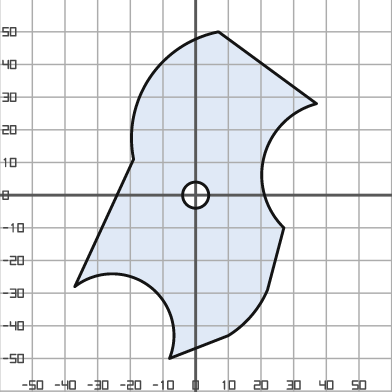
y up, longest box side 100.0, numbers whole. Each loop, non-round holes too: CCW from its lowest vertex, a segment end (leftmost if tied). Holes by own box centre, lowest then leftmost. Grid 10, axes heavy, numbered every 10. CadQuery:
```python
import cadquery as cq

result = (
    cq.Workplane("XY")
    .moveTo(-8.0, -50.0)
    .lineTo(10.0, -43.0)
    .threePointArc((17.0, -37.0), (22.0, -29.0))
    .lineTo(27.0, -10.0)
    .threePointArc((21.0, 12.0), (37.0, 28.0))
    .lineTo(7.0, 50.0)
    .threePointArc((-14.0, 36.0), (-19.0, 11.0))
    .lineTo(-37.0, -28.0)
    .threePointArc((-14.0, -28.0), (-8.0, -50.0))
    .close()
    .moveTo(0.0, 0.0)
    .circle(4.0)
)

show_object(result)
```